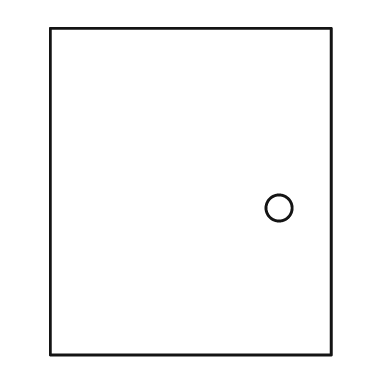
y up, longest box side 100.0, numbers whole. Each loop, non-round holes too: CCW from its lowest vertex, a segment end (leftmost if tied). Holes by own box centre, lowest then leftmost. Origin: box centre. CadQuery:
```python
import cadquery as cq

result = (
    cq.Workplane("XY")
    .moveTo(-43.0, -50.0)
    .lineTo(43.0, -50.0)
    .lineTo(43.0, 50.0)
    .lineTo(-43.0, 50.0)
    .close()
    .moveTo(27.0, -5.0)
    .circle(4.0)
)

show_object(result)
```